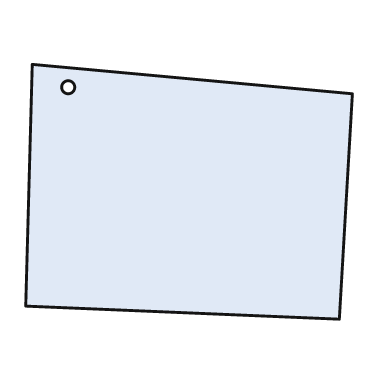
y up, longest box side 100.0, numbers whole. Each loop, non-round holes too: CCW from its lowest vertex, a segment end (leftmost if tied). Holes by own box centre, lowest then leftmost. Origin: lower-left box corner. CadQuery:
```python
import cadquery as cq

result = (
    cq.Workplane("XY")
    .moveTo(96.0, 0.0)
    .lineTo(100.0, 69.0)
    .lineTo(2.0, 78.0)
    .lineTo(0.0, 4.0)
    .close()
    .moveTo(13.0, 71.0)
    .circle(2.0)
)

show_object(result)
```